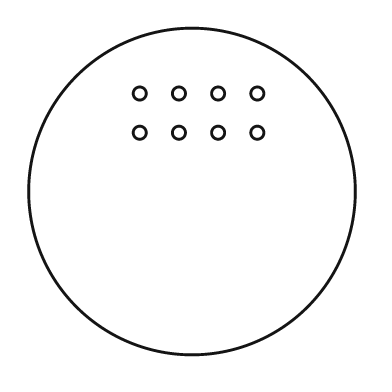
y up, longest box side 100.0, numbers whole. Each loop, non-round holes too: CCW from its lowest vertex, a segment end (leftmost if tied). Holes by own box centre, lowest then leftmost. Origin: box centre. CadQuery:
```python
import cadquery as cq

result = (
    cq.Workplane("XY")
    .moveTo(0.0, 0.0)
    .circle(50.0)
    .moveTo(-16.0, 18.0)
    .circle(2.0)
    .moveTo(-4.0, 18.0)
    .circle(2.0)
    .moveTo(8.0, 18.0)
    .circle(2.0)
    .moveTo(20.0, 18.0)
    .circle(2.0)
    .moveTo(-16.0, 30.0)
    .circle(2.0)
    .moveTo(-4.0, 30.0)
    .circle(2.0)
    .moveTo(8.0, 30.0)
    .circle(2.0)
    .moveTo(20.0, 30.0)
    .circle(2.0)
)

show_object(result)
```